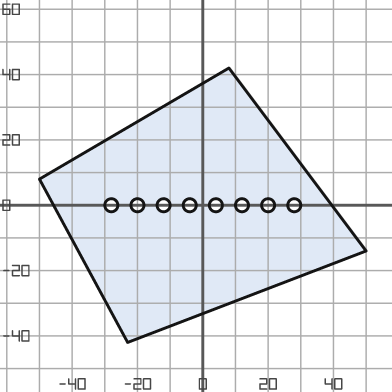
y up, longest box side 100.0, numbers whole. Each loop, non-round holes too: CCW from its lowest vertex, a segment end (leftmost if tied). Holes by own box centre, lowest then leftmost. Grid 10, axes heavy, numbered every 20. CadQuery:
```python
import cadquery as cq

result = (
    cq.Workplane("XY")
    .moveTo(-23.0, -42.0)
    .lineTo(50.0, -14.0)
    .lineTo(8.0, 42.0)
    .lineTo(-50.0, 8.0)
    .close()
    .moveTo(-28.0, 0.0)
    .circle(2.0)
    .moveTo(-20.0, 0.0)
    .circle(2.0)
    .moveTo(-12.0, 0.0)
    .circle(2.0)
    .moveTo(-4.0, 0.0)
    .circle(2.0)
    .moveTo(4.0, 0.0)
    .circle(2.0)
    .moveTo(12.0, 0.0)
    .circle(2.0)
    .moveTo(20.0, 0.0)
    .circle(2.0)
    .moveTo(28.0, 0.0)
    .circle(2.0)
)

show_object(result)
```